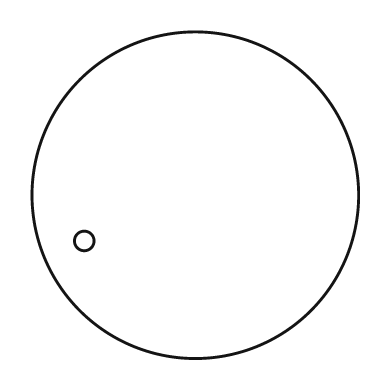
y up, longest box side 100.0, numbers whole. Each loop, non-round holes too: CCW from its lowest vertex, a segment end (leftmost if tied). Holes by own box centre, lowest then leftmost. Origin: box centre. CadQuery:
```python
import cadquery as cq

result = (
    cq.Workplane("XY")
    .moveTo(0.0, 0.0)
    .circle(50.0)
    .moveTo(-34.0, -14.0)
    .circle(3.0)
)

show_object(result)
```